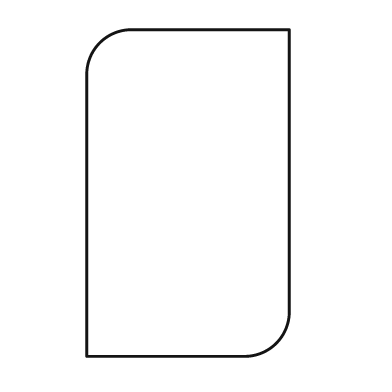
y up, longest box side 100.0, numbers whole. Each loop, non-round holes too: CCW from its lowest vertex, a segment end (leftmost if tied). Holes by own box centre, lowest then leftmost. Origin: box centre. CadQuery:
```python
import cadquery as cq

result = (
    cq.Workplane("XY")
    .moveTo(-31.0, -50.0)
    .lineTo(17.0, -50.0)
    .threePointArc((27.0, -46.0), (31.0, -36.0))
    .lineTo(31.0, 50.0)
    .lineTo(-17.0, 50.0)
    .threePointArc((-27.0, 46.0), (-31.0, 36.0))
    .close()
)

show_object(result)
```